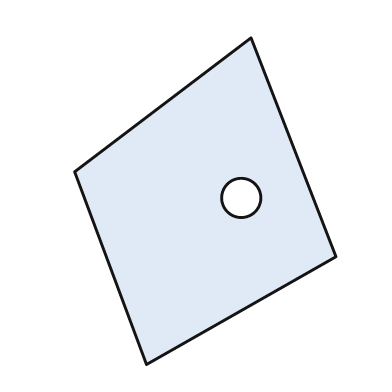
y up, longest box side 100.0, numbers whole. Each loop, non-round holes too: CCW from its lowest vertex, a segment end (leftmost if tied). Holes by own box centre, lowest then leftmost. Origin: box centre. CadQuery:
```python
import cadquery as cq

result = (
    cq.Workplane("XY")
    .moveTo(-18.0, -50.0)
    .lineTo(40.0, -17.0)
    .lineTo(14.0, 50.0)
    .lineTo(-40.0, 9.0)
    .close()
    .moveTo(11.0, 1.0)
    .circle(6.0)
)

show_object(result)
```